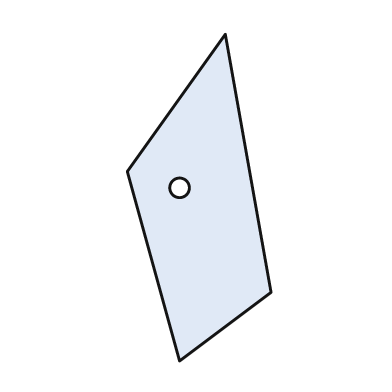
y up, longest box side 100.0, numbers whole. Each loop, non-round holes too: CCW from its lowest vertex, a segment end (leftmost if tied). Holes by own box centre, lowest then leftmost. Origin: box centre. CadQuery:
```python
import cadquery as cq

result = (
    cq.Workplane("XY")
    .moveTo(-6.0, -50.0)
    .lineTo(22.0, -29.0)
    .lineTo(8.0, 50.0)
    .lineTo(-22.0, 8.0)
    .close()
    .moveTo(-6.0, 3.0)
    .circle(3.0)
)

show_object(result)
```